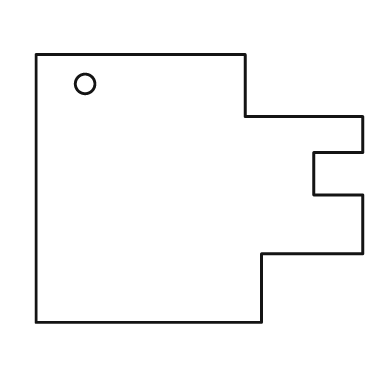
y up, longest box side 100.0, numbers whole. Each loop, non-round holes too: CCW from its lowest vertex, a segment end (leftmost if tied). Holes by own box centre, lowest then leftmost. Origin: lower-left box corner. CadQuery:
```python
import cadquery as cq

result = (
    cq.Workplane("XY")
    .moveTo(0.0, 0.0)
    .lineTo(69.0, 0.0)
    .lineTo(69.0, 21.0)
    .lineTo(100.0, 21.0)
    .lineTo(100.0, 39.0)
    .lineTo(85.0, 39.0)
    .lineTo(85.0, 52.0)
    .lineTo(100.0, 52.0)
    .lineTo(100.0, 63.0)
    .lineTo(64.0, 63.0)
    .lineTo(64.0, 82.0)
    .lineTo(0.0, 82.0)
    .close()
    .moveTo(15.0, 73.0)
    .circle(3.0)
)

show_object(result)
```